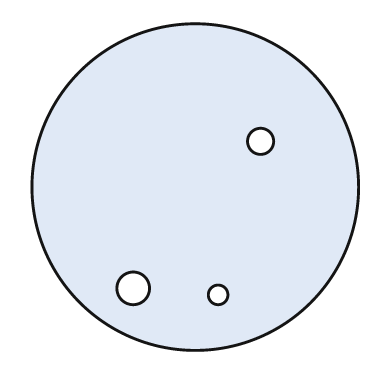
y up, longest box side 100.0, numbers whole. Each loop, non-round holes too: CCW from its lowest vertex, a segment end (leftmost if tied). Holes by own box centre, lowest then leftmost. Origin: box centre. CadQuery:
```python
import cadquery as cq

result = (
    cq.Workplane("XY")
    .moveTo(0.0, 0.0)
    .circle(50.0)
    .moveTo(7.0, -33.0)
    .circle(3.0)
    .moveTo(-19.0, -31.0)
    .circle(5.0)
    .moveTo(20.0, 14.0)
    .circle(4.0)
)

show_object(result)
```